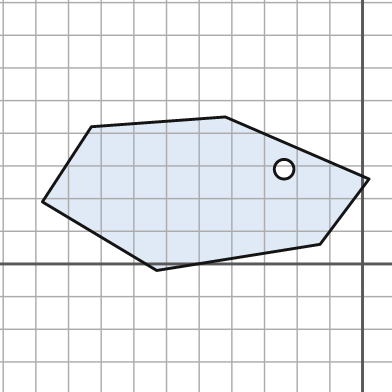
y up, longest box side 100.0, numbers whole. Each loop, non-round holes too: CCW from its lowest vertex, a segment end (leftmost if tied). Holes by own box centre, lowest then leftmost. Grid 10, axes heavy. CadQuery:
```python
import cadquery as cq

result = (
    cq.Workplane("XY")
    .moveTo(-63.0, -2.0)
    .lineTo(-13.0, 6.0)
    .lineTo(2.0, 26.0)
    .lineTo(-42.0, 45.0)
    .lineTo(-83.0, 42.0)
    .lineTo(-98.0, 19.0)
    .close()
    .moveTo(-24.0, 29.0)
    .circle(3.0)
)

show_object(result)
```